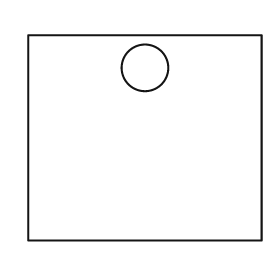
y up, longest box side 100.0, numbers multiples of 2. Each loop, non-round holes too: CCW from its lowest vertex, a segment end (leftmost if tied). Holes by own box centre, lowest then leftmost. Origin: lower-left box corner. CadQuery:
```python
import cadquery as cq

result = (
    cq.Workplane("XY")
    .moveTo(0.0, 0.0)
    .lineTo(100.0, 0.0)
    .lineTo(100.0, 88.0)
    .lineTo(0.0, 88.0)
    .close()
    .moveTo(50.0, 74.0)
    .circle(10.0)
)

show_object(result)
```